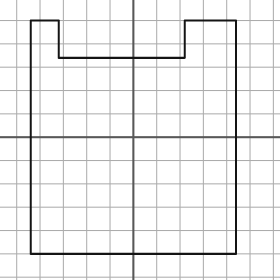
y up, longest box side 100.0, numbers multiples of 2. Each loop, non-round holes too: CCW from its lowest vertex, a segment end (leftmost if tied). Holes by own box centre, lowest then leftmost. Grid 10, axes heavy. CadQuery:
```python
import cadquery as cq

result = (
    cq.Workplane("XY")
    .moveTo(-44.0, -50.0)
    .lineTo(44.0, -50.0)
    .lineTo(44.0, 50.0)
    .lineTo(22.0, 50.0)
    .lineTo(22.0, 34.0)
    .lineTo(-32.0, 34.0)
    .lineTo(-32.0, 50.0)
    .lineTo(-44.0, 50.0)
    .close()
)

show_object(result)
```